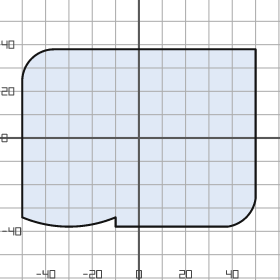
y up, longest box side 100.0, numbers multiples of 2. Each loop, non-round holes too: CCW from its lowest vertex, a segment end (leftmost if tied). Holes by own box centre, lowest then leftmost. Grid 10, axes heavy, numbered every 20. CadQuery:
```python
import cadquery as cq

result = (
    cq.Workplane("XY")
    .moveTo(-10.0, -38.0)
    .lineTo(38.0, -38.0)
    .threePointArc((46.0, -34.0), (50.0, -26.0))
    .lineTo(50.0, 38.0)
    .lineTo(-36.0, 38.0)
    .threePointArc((-46.0, 34.0), (-50.0, 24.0))
    .lineTo(-50.0, -34.0)
    .threePointArc((-30.0, -38.0), (-10.0, -34.0))
    .close()
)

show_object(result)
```